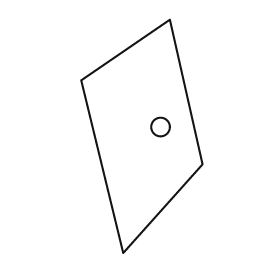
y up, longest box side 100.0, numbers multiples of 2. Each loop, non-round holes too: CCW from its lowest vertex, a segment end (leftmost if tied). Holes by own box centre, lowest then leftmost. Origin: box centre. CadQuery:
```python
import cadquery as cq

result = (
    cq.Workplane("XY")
    .moveTo(-8.0, -50.0)
    .lineTo(26.0, -12.0)
    .lineTo(12.0, 50.0)
    .lineTo(-26.0, 24.0)
    .close()
    .moveTo(8.0, 4.0)
    .circle(4.0)
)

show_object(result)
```